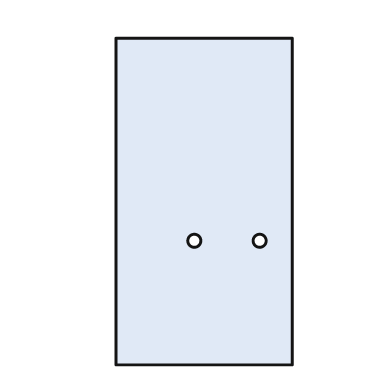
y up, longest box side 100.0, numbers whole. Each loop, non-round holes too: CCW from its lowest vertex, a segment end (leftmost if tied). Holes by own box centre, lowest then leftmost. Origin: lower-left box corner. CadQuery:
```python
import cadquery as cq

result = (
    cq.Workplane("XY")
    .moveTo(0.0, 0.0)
    .lineTo(54.0, 0.0)
    .lineTo(54.0, 100.0)
    .lineTo(0.0, 100.0)
    .close()
    .moveTo(24.0, 38.0)
    .circle(2.0)
    .moveTo(44.0, 38.0)
    .circle(2.0)
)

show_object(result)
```